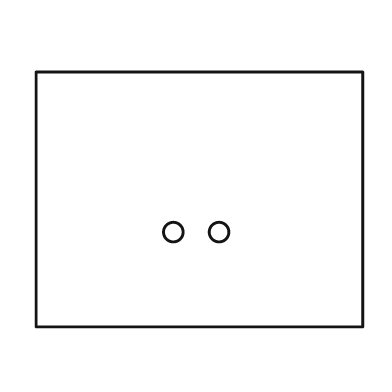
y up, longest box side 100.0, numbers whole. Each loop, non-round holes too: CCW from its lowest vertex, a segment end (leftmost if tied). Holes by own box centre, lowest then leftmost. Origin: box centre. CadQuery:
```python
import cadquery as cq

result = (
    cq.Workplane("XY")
    .moveTo(-50.0, -39.0)
    .lineTo(50.0, -39.0)
    .lineTo(50.0, 39.0)
    .lineTo(-50.0, 39.0)
    .close()
    .moveTo(-8.0, -10.0)
    .circle(3.0)
    .moveTo(6.0, -10.0)
    .circle(3.0)
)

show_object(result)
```